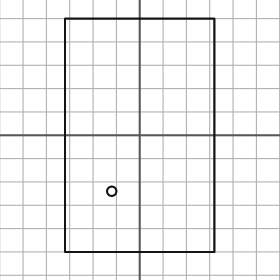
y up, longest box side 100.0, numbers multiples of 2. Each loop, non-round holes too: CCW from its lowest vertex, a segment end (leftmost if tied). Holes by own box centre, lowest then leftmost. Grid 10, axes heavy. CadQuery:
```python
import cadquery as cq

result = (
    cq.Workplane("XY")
    .moveTo(-32.0, -50.0)
    .lineTo(32.0, -50.0)
    .lineTo(32.0, 50.0)
    .lineTo(-32.0, 50.0)
    .close()
    .moveTo(-12.0, -24.0)
    .circle(2.0)
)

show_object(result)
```